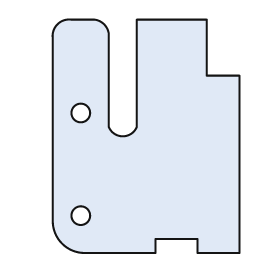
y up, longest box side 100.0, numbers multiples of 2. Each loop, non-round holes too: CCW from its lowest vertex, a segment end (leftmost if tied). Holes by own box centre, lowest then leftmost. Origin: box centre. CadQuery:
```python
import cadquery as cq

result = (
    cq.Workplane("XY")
    .moveTo(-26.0, -50.0)
    .lineTo(4.0, -50.0)
    .lineTo(4.0, -44.0)
    .lineTo(22.0, -44.0)
    .lineTo(22.0, -50.0)
    .lineTo(40.0, -50.0)
    .lineTo(40.0, 26.0)
    .lineTo(26.0, 26.0)
    .lineTo(26.0, 50.0)
    .lineTo(-4.0, 50.0)
    .lineTo(-4.0, 4.0)
    .threePointArc((-10.0, 0.0), (-16.0, 4.0))
    .lineTo(-16.0, 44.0)
    .threePointArc((-18.0, 48.0), (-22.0, 50.0))
    .lineTo(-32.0, 50.0)
    .threePointArc((-38.0, 48.0), (-40.0, 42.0))
    .lineTo(-40.0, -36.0)
    .threePointArc((-36.0, -46.0), (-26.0, -50.0))
    .close()
    .moveTo(-28.0, -34.0)
    .circle(4.0)
    .moveTo(-28.0, 10.0)
    .circle(4.0)
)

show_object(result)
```